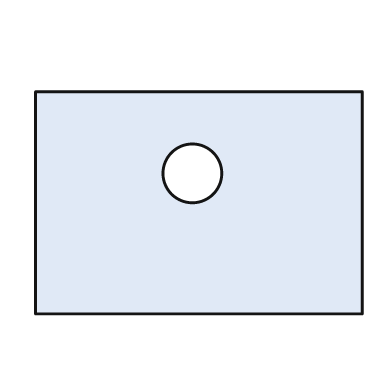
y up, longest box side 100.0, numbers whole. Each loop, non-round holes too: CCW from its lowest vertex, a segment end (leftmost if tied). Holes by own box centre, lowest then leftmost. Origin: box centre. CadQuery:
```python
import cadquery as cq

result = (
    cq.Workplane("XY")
    .moveTo(-50.0, -34.0)
    .lineTo(50.0, -34.0)
    .lineTo(50.0, 34.0)
    .lineTo(-50.0, 34.0)
    .close()
    .moveTo(-2.0, 9.0)
    .circle(9.0)
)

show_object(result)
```